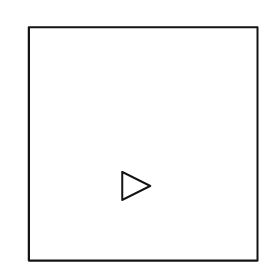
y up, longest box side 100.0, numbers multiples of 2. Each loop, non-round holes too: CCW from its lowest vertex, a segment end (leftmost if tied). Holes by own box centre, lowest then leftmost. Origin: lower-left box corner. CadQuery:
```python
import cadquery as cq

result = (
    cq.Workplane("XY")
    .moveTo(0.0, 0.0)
    .lineTo(98.0, 0.0)
    .lineTo(98.0, 100.0)
    .lineTo(0.0, 100.0)
    .close()
    .moveTo(40.0, 26.0)
    .lineTo(52.0, 32.0)
    .lineTo(40.0, 38.0)
    .close()
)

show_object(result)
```